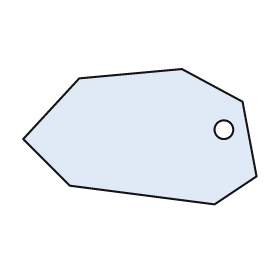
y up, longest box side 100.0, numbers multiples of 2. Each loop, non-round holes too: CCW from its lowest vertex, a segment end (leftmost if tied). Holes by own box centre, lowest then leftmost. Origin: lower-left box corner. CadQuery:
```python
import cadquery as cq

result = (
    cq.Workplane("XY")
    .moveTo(82.0, 0.0)
    .lineTo(100.0, 12.0)
    .lineTo(94.0, 44.0)
    .lineTo(68.0, 58.0)
    .lineTo(24.0, 54.0)
    .lineTo(0.0, 28.0)
    .lineTo(20.0, 8.0)
    .close()
    .moveTo(86.0, 32.0)
    .circle(4.0)
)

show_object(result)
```